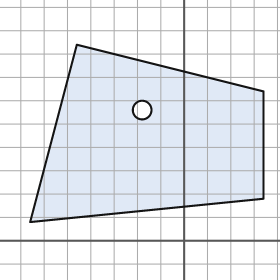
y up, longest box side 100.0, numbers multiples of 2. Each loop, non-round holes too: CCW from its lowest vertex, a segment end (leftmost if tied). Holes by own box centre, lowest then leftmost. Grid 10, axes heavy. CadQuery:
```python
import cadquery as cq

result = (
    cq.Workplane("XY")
    .moveTo(-66.0, 8.0)
    .lineTo(34.0, 18.0)
    .lineTo(34.0, 64.0)
    .lineTo(-46.0, 84.0)
    .close()
    .moveTo(-18.0, 56.0)
    .circle(4.0)
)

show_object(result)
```